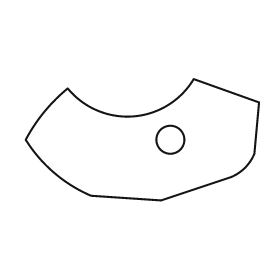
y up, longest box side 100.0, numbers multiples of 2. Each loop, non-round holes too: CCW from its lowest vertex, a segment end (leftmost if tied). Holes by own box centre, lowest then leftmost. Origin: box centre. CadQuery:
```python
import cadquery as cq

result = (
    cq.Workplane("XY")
    .moveTo(8.0, -26.0)
    .lineTo(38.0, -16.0)
    .threePointArc((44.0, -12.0), (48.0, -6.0))
    .lineTo(50.0, 16.0)
    .lineTo(22.0, 26.0)
    .threePointArc((-4.0, 10.0), (-32.0, 22.0))
    .threePointArc((-42.0, 12.0), (-50.0, 0.0))
    .threePointArc((-38.0, -14.0), (-22.0, -24.0))
    .close()
    .moveTo(12.0, 0.0)
    .circle(6.0)
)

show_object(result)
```